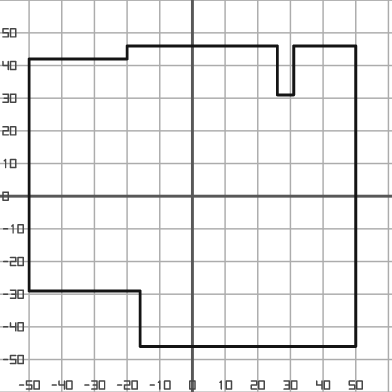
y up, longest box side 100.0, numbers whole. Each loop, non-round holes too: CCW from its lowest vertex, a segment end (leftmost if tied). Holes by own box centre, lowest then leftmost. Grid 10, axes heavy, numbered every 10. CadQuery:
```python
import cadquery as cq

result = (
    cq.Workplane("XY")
    .moveTo(-16.0, -46.0)
    .lineTo(50.0, -46.0)
    .lineTo(50.0, 46.0)
    .lineTo(31.0, 46.0)
    .lineTo(31.0, 31.0)
    .lineTo(26.0, 31.0)
    .lineTo(26.0, 46.0)
    .lineTo(-20.0, 46.0)
    .lineTo(-20.0, 42.0)
    .lineTo(-50.0, 42.0)
    .lineTo(-50.0, -29.0)
    .lineTo(-16.0, -29.0)
    .close()
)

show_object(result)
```